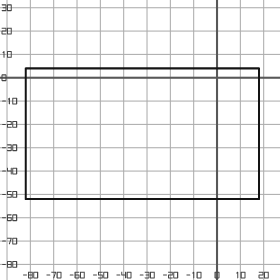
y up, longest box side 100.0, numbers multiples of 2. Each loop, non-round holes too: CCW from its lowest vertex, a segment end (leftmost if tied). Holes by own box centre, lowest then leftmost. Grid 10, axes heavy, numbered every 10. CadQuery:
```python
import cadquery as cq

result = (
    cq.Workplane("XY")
    .moveTo(-82.0, -52.0)
    .lineTo(18.0, -52.0)
    .lineTo(18.0, 4.0)
    .lineTo(-82.0, 4.0)
    .close()
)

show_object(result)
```